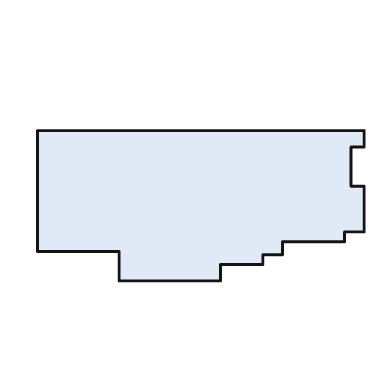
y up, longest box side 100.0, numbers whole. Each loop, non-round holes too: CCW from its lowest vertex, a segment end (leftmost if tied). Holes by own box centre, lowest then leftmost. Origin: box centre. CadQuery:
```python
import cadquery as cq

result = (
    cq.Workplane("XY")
    .moveTo(-25.0, -23.0)
    .lineTo(6.0, -23.0)
    .lineTo(6.0, -18.0)
    .lineTo(19.0, -18.0)
    .lineTo(19.0, -15.0)
    .lineTo(25.0, -15.0)
    .lineTo(25.0, -11.0)
    .lineTo(44.0, -11.0)
    .lineTo(44.0, -8.0)
    .lineTo(50.0, -8.0)
    .lineTo(50.0, 6.0)
    .lineTo(46.0, 6.0)
    .lineTo(46.0, 18.0)
    .lineTo(50.0, 18.0)
    .lineTo(50.0, 23.0)
    .lineTo(-50.0, 23.0)
    .lineTo(-50.0, -14.0)
    .lineTo(-25.0, -14.0)
    .close()
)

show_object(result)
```